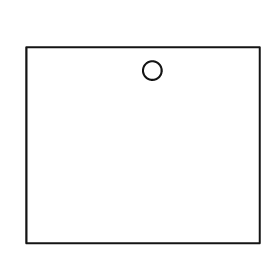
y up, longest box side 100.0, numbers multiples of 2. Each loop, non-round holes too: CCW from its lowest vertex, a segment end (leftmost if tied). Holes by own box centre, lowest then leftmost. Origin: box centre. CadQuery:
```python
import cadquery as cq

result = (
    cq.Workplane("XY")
    .moveTo(-50.0, -42.0)
    .lineTo(50.0, -42.0)
    .lineTo(50.0, 42.0)
    .lineTo(-50.0, 42.0)
    .close()
    .moveTo(4.0, 32.0)
    .circle(4.0)
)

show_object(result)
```